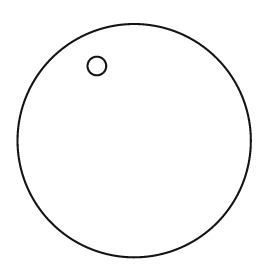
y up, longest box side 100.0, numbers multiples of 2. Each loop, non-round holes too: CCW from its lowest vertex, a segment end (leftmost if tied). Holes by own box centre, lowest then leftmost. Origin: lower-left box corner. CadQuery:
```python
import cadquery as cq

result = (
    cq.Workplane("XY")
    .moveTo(50.0, 50.0)
    .circle(50.0)
    .moveTo(34.0, 82.0)
    .circle(4.0)
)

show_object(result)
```